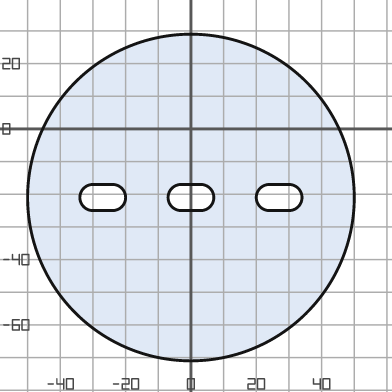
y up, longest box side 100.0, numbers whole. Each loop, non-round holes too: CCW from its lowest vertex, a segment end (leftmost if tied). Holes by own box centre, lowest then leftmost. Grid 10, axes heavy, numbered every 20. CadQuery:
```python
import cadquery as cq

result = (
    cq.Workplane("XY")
    .moveTo(0.0, -21.0)
    .circle(50.0)
    .moveTo(-30.0, -25.0)
    .lineTo(-24.0, -25.0)
    .threePointArc((-20.0, -21.0), (-24.0, -17.0))
    .lineTo(-30.0, -17.0)
    .threePointArc((-34.0, -21.0), (-30.0, -25.0))
    .close()
    .moveTo(-3.0, -25.0)
    .lineTo(3.0, -25.0)
    .threePointArc((7.0, -21.0), (3.0, -17.0))
    .lineTo(-3.0, -17.0)
    .threePointArc((-7.0, -21.0), (-3.0, -25.0))
    .close()
    .moveTo(24.0, -25.0)
    .lineTo(30.0, -25.0)
    .threePointArc((34.0, -21.0), (30.0, -17.0))
    .lineTo(24.0, -17.0)
    .threePointArc((20.0, -21.0), (24.0, -25.0))
    .close()
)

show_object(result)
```